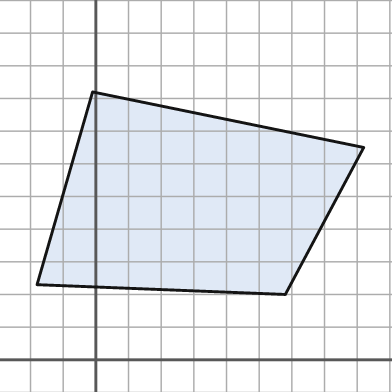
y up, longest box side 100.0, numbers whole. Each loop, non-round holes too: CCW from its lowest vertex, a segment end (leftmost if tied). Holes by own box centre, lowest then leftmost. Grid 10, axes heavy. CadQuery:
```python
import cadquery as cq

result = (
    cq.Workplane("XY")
    .moveTo(58.0, 20.0)
    .lineTo(82.0, 65.0)
    .lineTo(-1.0, 82.0)
    .lineTo(-18.0, 23.0)
    .close()
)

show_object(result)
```